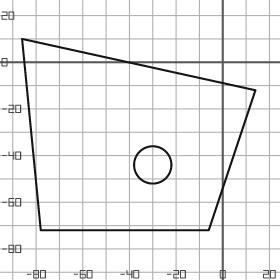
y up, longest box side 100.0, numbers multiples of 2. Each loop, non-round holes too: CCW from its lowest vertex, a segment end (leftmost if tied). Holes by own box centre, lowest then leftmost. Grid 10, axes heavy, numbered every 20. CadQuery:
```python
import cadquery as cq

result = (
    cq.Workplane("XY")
    .moveTo(-78.0, -72.0)
    .lineTo(-6.0, -72.0)
    .lineTo(14.0, -12.0)
    .lineTo(-86.0, 10.0)
    .close()
    .moveTo(-30.0, -44.0)
    .circle(8.0)
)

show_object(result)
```